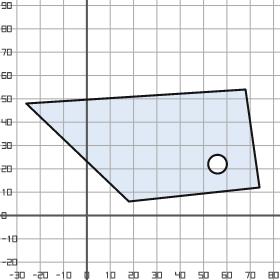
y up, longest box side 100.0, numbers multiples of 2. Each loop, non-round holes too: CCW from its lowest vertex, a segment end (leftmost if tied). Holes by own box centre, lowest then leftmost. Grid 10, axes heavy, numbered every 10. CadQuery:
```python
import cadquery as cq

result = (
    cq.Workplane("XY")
    .moveTo(18.0, 6.0)
    .lineTo(74.0, 12.0)
    .lineTo(68.0, 54.0)
    .lineTo(-26.0, 48.0)
    .close()
    .moveTo(56.0, 22.0)
    .circle(4.0)
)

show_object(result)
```